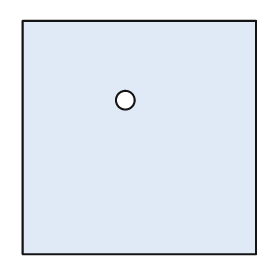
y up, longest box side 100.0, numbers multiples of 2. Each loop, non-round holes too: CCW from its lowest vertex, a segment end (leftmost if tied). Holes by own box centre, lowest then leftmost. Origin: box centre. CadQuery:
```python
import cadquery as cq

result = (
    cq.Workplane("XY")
    .moveTo(-50.0, -50.0)
    .lineTo(50.0, -50.0)
    .lineTo(50.0, 50.0)
    .lineTo(-50.0, 50.0)
    .close()
    .moveTo(-6.0, 16.0)
    .circle(4.0)
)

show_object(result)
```